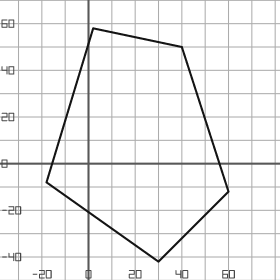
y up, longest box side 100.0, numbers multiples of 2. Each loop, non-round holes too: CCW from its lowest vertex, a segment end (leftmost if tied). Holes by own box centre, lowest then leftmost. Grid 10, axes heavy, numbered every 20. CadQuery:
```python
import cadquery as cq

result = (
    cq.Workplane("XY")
    .moveTo(30.0, -42.0)
    .lineTo(60.0, -12.0)
    .lineTo(40.0, 50.0)
    .lineTo(2.0, 58.0)
    .lineTo(-18.0, -8.0)
    .close()
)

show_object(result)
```